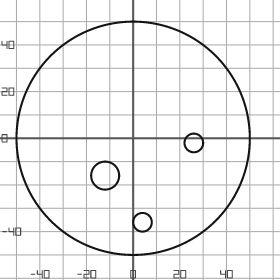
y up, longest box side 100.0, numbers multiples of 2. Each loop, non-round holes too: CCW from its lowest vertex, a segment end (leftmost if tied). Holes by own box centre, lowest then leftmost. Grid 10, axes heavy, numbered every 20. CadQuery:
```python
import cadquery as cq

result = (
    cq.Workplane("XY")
    .moveTo(0.0, 0.0)
    .circle(50.0)
    .moveTo(4.0, -36.0)
    .circle(4.0)
    .moveTo(-12.0, -16.0)
    .circle(6.0)
    .moveTo(26.0, -2.0)
    .circle(4.0)
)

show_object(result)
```